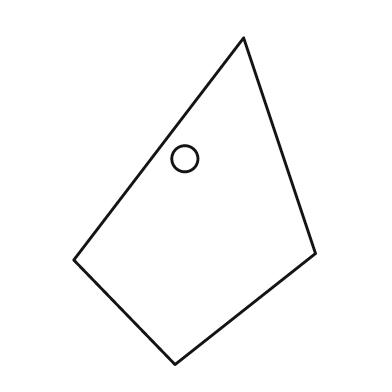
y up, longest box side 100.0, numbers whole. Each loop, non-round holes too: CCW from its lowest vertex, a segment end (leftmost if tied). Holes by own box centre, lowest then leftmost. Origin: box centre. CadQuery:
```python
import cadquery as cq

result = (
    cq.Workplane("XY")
    .moveTo(-6.0, -50.0)
    .lineTo(37.0, -16.0)
    .lineTo(15.0, 50.0)
    .lineTo(-37.0, -18.0)
    .close()
    .moveTo(-3.0, 13.0)
    .circle(4.0)
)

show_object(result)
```